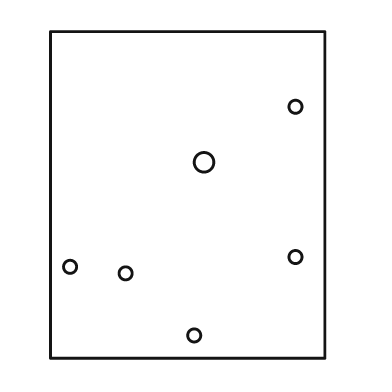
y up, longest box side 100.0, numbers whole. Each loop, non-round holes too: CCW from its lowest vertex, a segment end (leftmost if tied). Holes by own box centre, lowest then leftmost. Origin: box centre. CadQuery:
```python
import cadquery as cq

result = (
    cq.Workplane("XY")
    .moveTo(-42.0, -50.0)
    .lineTo(42.0, -50.0)
    .lineTo(42.0, 50.0)
    .lineTo(-42.0, 50.0)
    .close()
    .moveTo(2.0, -43.0)
    .circle(2.0)
    .moveTo(-19.0, -24.0)
    .circle(2.0)
    .moveTo(-36.0, -22.0)
    .circle(2.0)
    .moveTo(33.0, -19.0)
    .circle(2.0)
    .moveTo(5.0, 10.0)
    .circle(3.0)
    .moveTo(33.0, 27.0)
    .circle(2.0)
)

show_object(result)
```